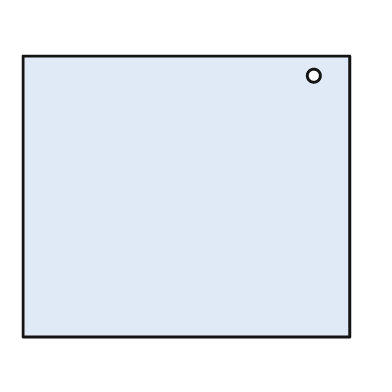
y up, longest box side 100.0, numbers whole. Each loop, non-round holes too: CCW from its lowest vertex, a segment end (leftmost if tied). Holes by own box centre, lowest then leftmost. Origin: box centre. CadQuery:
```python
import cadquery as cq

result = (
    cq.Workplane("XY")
    .moveTo(-50.0, -43.0)
    .lineTo(50.0, -43.0)
    .lineTo(50.0, 43.0)
    .lineTo(-50.0, 43.0)
    .close()
    .moveTo(39.0, 37.0)
    .circle(2.0)
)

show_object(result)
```